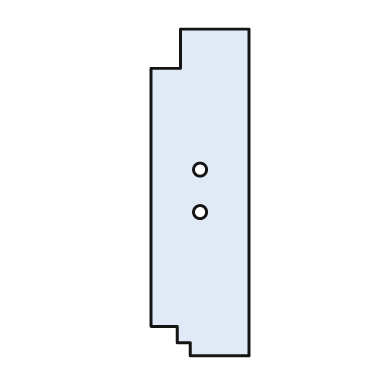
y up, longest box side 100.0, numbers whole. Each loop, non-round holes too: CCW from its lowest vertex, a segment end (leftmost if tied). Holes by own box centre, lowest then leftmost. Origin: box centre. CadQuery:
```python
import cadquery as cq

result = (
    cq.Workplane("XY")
    .moveTo(-3.0, -50.0)
    .lineTo(15.0, -50.0)
    .lineTo(15.0, 50.0)
    .lineTo(-6.0, 50.0)
    .lineTo(-6.0, 38.0)
    .lineTo(-15.0, 38.0)
    .lineTo(-15.0, -41.0)
    .lineTo(-7.0, -41.0)
    .lineTo(-7.0, -46.0)
    .lineTo(-3.0, -46.0)
    .close()
    .moveTo(0.0, -6.0)
    .circle(2.0)
    .moveTo(0.0, 7.0)
    .circle(2.0)
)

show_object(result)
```